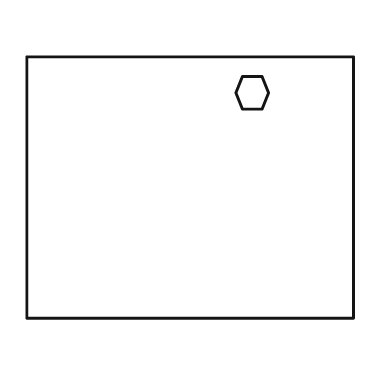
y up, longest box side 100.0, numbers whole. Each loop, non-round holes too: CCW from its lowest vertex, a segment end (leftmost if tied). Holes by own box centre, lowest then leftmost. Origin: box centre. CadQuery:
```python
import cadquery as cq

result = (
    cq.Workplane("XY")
    .moveTo(-50.0, -40.0)
    .lineTo(50.0, -40.0)
    .lineTo(50.0, 40.0)
    .lineTo(-50.0, 40.0)
    .close()
    .moveTo(16.0, 24.0)
    .lineTo(22.0, 24.0)
    .lineTo(24.0, 29.0)
    .lineTo(22.0, 34.0)
    .lineTo(16.0, 34.0)
    .lineTo(14.0, 29.0)
    .close()
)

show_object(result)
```